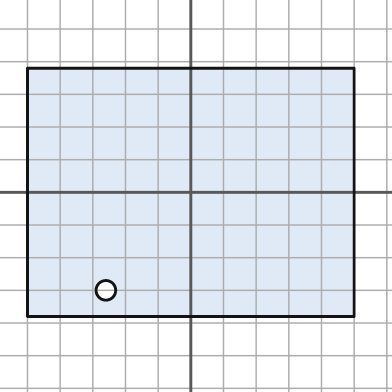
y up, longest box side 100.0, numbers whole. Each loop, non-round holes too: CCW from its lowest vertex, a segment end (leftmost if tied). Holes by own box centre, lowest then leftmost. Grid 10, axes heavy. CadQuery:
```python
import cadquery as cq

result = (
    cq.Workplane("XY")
    .moveTo(-50.0, -38.0)
    .lineTo(50.0, -38.0)
    .lineTo(50.0, 38.0)
    .lineTo(-50.0, 38.0)
    .close()
    .moveTo(-26.0, -30.0)
    .circle(3.0)
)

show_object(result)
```